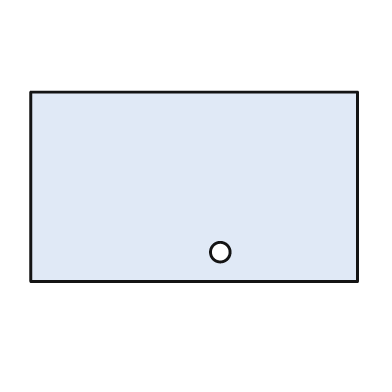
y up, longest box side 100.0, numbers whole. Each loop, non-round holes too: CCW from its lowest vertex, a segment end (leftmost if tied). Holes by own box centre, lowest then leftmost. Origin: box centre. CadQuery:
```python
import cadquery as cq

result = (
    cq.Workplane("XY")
    .moveTo(-50.0, -29.0)
    .lineTo(50.0, -29.0)
    .lineTo(50.0, 29.0)
    .lineTo(-50.0, 29.0)
    .close()
    .moveTo(8.0, -20.0)
    .circle(3.0)
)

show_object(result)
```